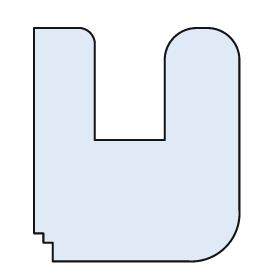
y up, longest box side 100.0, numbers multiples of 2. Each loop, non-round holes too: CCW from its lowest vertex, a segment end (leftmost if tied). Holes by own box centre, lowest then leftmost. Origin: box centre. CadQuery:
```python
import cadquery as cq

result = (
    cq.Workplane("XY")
    .moveTo(-36.0, -50.0)
    .lineTo(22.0, -50.0)
    .threePointArc((38.0, -44.0), (44.0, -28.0))
    .lineTo(44.0, 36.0)
    .threePointArc((40.0, 46.0), (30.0, 50.0))
    .lineTo(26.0, 50.0)
    .threePointArc((16.0, 46.0), (12.0, 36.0))
    .lineTo(12.0, 2.0)
    .lineTo(-18.0, 2.0)
    .lineTo(-18.0, 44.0)
    .threePointArc((-20.0, 48.0), (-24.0, 50.0))
    .lineTo(-44.0, 50.0)
    .lineTo(-44.0, -38.0)
    .lineTo(-40.0, -38.0)
    .lineTo(-40.0, -42.0)
    .lineTo(-36.0, -42.0)
    .close()
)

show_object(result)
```